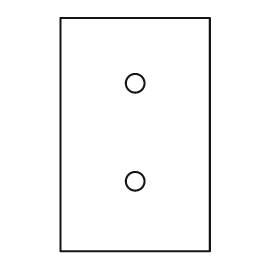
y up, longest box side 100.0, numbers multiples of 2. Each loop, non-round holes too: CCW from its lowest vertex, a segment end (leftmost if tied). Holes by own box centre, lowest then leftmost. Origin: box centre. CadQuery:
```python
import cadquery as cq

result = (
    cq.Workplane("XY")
    .moveTo(-32.0, -50.0)
    .lineTo(32.0, -50.0)
    .lineTo(32.0, 50.0)
    .lineTo(-32.0, 50.0)
    .close()
    .moveTo(0.0, -20.0)
    .circle(4.0)
    .moveTo(0.0, 22.0)
    .circle(4.0)
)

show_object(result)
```